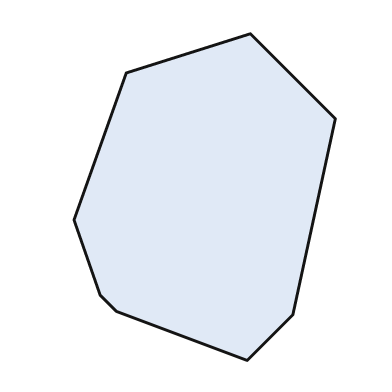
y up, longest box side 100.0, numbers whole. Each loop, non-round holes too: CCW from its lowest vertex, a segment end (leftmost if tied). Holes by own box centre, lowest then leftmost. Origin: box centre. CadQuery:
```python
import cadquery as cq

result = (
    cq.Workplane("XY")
    .moveTo(13.0, -50.0)
    .lineTo(27.0, -36.0)
    .lineTo(40.0, 24.0)
    .lineTo(14.0, 50.0)
    .lineTo(-24.0, 38.0)
    .lineTo(-40.0, -7.0)
    .lineTo(-32.0, -30.0)
    .lineTo(-27.0, -35.0)
    .close()
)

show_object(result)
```